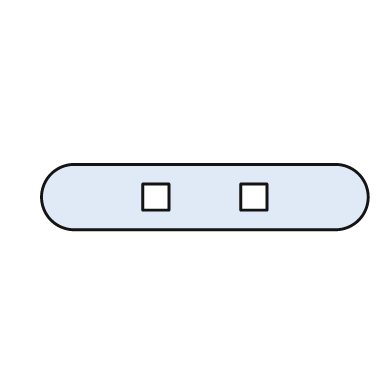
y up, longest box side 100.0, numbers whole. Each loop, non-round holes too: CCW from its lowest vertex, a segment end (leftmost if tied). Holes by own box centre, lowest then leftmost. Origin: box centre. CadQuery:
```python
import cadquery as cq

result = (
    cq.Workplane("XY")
    .moveTo(-40.0, -10.0)
    .lineTo(40.0, -10.0)
    .threePointArc((50.0, 0.0), (40.0, 10.0))
    .lineTo(-40.0, 10.0)
    .threePointArc((-50.0, 0.0), (-40.0, -10.0))
    .close()
    .moveTo(-19.0, -4.0)
    .lineTo(-11.0, -4.0)
    .lineTo(-11.0, 4.0)
    .lineTo(-19.0, 4.0)
    .close()
    .moveTo(11.0, -4.0)
    .lineTo(19.0, -4.0)
    .lineTo(19.0, 4.0)
    .lineTo(11.0, 4.0)
    .close()
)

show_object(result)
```